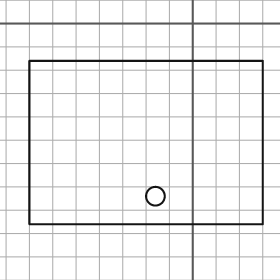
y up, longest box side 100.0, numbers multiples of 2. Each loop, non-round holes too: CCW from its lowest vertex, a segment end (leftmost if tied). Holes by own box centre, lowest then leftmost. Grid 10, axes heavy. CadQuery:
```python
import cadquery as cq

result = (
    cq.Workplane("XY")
    .moveTo(-70.0, -86.0)
    .lineTo(30.0, -86.0)
    .lineTo(30.0, -16.0)
    .lineTo(-70.0, -16.0)
    .close()
    .moveTo(-16.0, -74.0)
    .circle(4.0)
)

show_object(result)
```